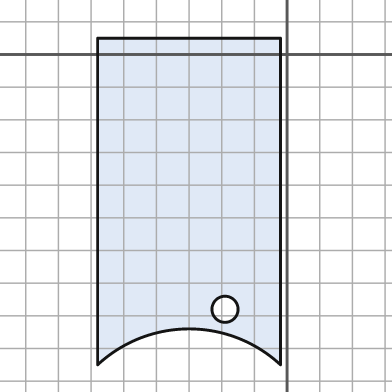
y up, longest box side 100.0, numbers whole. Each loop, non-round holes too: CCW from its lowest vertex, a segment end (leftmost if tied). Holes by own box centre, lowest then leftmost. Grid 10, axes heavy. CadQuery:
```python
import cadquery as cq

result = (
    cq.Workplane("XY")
    .moveTo(-58.0, -95.0)
    .threePointArc((-30.0, -84.0), (-2.0, -95.0))
    .lineTo(-2.0, 5.0)
    .lineTo(-58.0, 5.0)
    .close()
    .moveTo(-19.0, -78.0)
    .circle(4.0)
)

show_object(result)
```